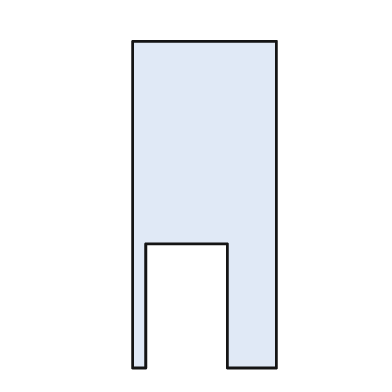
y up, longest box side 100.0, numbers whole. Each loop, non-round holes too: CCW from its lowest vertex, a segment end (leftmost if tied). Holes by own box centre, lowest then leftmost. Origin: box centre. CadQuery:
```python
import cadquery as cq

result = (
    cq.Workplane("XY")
    .moveTo(-22.0, -50.0)
    .lineTo(-18.0, -50.0)
    .lineTo(-18.0, -12.0)
    .lineTo(7.0, -12.0)
    .lineTo(7.0, -50.0)
    .lineTo(22.0, -50.0)
    .lineTo(22.0, 50.0)
    .lineTo(-22.0, 50.0)
    .close()
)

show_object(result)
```